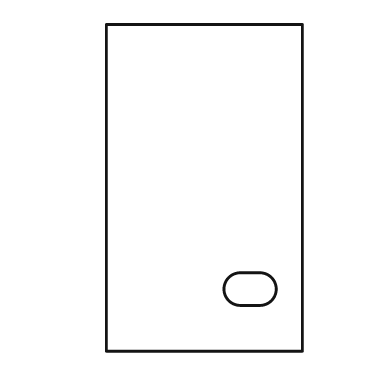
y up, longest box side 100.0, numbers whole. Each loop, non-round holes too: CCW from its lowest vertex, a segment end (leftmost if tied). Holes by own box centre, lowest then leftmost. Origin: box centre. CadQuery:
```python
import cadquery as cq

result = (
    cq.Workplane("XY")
    .moveTo(-30.0, -50.0)
    .lineTo(30.0, -50.0)
    .lineTo(30.0, 50.0)
    .lineTo(-30.0, 50.0)
    .close()
    .moveTo(11.0, -36.0)
    .lineTo(17.0, -36.0)
    .threePointArc((22.0, -31.0), (17.0, -26.0))
    .lineTo(11.0, -26.0)
    .threePointArc((6.0, -31.0), (11.0, -36.0))
    .close()
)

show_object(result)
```